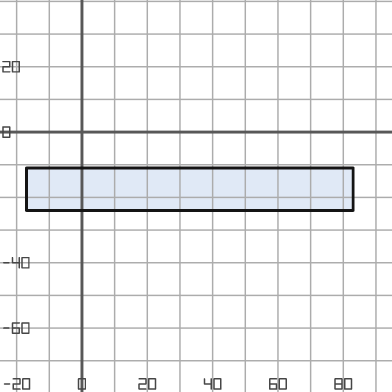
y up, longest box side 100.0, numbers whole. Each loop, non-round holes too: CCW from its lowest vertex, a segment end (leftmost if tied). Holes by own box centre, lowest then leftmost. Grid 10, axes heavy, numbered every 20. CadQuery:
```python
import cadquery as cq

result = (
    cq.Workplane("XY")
    .moveTo(-17.0, -24.0)
    .lineTo(83.0, -24.0)
    .lineTo(83.0, -11.0)
    .lineTo(-17.0, -11.0)
    .close()
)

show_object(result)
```